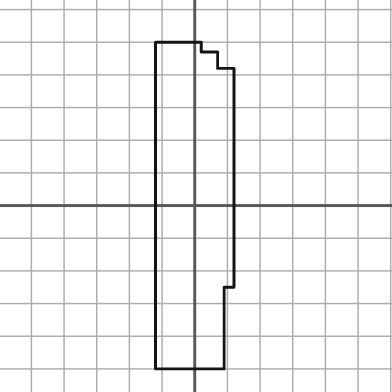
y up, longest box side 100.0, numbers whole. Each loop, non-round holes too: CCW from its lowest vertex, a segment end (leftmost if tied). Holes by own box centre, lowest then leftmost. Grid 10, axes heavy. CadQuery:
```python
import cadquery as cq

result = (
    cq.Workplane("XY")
    .moveTo(-12.0, -50.0)
    .lineTo(9.0, -50.0)
    .lineTo(9.0, -25.0)
    .lineTo(12.0, -25.0)
    .lineTo(12.0, 42.0)
    .lineTo(7.0, 42.0)
    .lineTo(7.0, 47.0)
    .lineTo(2.0, 47.0)
    .lineTo(2.0, 50.0)
    .lineTo(-12.0, 50.0)
    .close()
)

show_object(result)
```